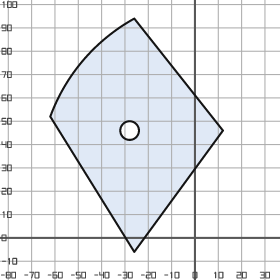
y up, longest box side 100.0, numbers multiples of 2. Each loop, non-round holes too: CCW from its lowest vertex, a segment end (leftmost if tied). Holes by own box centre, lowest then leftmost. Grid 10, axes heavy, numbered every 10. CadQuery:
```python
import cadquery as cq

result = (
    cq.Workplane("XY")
    .moveTo(-26.0, -6.0)
    .lineTo(12.0, 46.0)
    .lineTo(-26.0, 94.0)
    .threePointArc((-48.0, 76.0), (-62.0, 52.0))
    .close()
    .moveTo(-28.0, 46.0)
    .circle(4.0)
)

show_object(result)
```